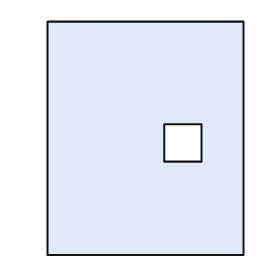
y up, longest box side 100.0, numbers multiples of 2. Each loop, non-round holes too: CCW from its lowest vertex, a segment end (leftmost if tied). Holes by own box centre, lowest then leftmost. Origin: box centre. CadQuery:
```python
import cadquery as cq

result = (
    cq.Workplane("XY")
    .moveTo(-42.0, -50.0)
    .lineTo(42.0, -50.0)
    .lineTo(42.0, 50.0)
    .lineTo(-42.0, 50.0)
    .close()
    .moveTo(8.0, -10.0)
    .lineTo(24.0, -10.0)
    .lineTo(24.0, 6.0)
    .lineTo(8.0, 6.0)
    .close()
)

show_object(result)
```